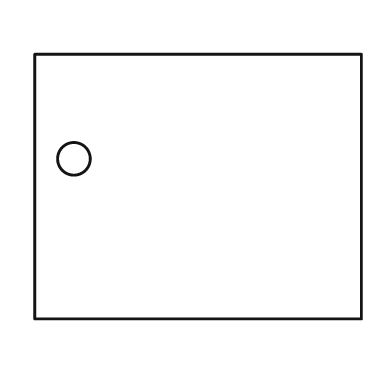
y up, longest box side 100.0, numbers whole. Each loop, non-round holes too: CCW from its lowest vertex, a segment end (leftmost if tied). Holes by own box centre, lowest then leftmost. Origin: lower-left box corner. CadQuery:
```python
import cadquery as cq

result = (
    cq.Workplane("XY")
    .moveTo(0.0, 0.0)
    .lineTo(100.0, 0.0)
    .lineTo(100.0, 81.0)
    .lineTo(0.0, 81.0)
    .close()
    .moveTo(12.0, 49.0)
    .circle(5.0)
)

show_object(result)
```